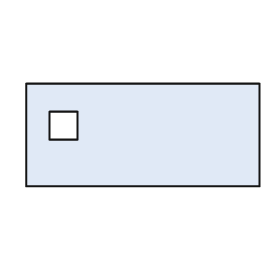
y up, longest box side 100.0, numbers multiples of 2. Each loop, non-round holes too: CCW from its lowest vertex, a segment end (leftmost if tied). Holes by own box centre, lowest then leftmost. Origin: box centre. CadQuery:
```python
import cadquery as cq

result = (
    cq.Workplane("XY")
    .moveTo(-50.0, -22.0)
    .lineTo(50.0, -22.0)
    .lineTo(50.0, 22.0)
    .lineTo(-50.0, 22.0)
    .close()
    .moveTo(-40.0, -2.0)
    .lineTo(-28.0, -2.0)
    .lineTo(-28.0, 10.0)
    .lineTo(-40.0, 10.0)
    .close()
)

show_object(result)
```